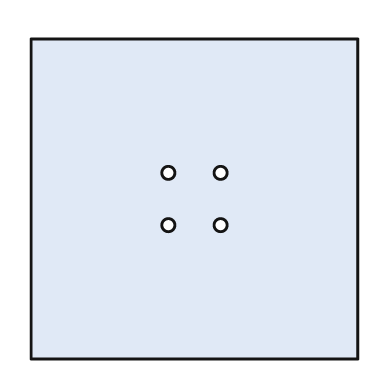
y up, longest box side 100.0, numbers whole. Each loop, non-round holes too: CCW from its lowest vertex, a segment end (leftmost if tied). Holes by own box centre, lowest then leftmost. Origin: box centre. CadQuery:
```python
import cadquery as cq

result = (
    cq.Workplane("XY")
    .moveTo(-50.0, -49.0)
    .lineTo(50.0, -49.0)
    .lineTo(50.0, 49.0)
    .lineTo(-50.0, 49.0)
    .close()
    .moveTo(-8.0, -8.0)
    .circle(2.0)
    .moveTo(8.0, -8.0)
    .circle(2.0)
    .moveTo(-8.0, 8.0)
    .circle(2.0)
    .moveTo(8.0, 8.0)
    .circle(2.0)
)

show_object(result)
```